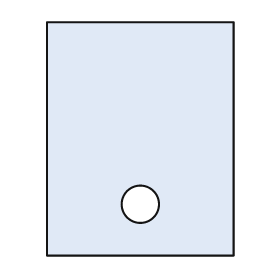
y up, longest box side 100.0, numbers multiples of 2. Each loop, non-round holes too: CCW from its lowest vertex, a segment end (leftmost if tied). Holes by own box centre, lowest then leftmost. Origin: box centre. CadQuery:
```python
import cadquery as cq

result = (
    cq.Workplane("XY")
    .moveTo(-40.0, -50.0)
    .lineTo(40.0, -50.0)
    .lineTo(40.0, 50.0)
    .lineTo(-40.0, 50.0)
    .close()
    .moveTo(0.0, -28.0)
    .circle(8.0)
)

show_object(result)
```